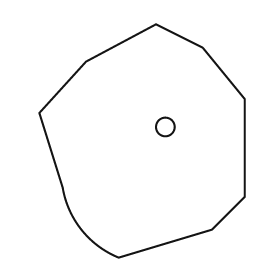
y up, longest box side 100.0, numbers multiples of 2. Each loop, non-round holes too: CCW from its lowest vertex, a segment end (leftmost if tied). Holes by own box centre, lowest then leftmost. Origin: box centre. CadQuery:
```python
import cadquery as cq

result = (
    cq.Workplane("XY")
    .moveTo(-10.0, -50.0)
    .lineTo(30.0, -38.0)
    .lineTo(44.0, -24.0)
    .lineTo(44.0, 18.0)
    .lineTo(26.0, 40.0)
    .lineTo(6.0, 50.0)
    .lineTo(-24.0, 34.0)
    .lineTo(-44.0, 12.0)
    .lineTo(-34.0, -20.0)
    .threePointArc((-26.0, -38.0), (-10.0, -50.0))
    .close()
    .moveTo(10.0, 6.0)
    .circle(4.0)
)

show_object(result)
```